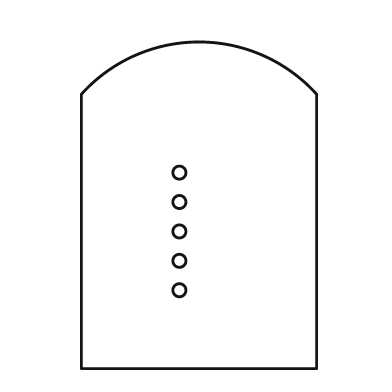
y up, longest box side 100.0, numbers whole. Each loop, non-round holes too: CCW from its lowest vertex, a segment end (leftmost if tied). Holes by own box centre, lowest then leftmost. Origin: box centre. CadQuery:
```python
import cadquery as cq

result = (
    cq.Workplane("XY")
    .moveTo(-36.0, -50.0)
    .lineTo(36.0, -50.0)
    .lineTo(36.0, 34.0)
    .threePointArc((0.0, 50.0), (-36.0, 34.0))
    .close()
    .moveTo(-6.0, -26.0)
    .circle(2.0)
    .moveTo(-6.0, -17.0)
    .circle(2.0)
    .moveTo(-6.0, -8.0)
    .circle(2.0)
    .moveTo(-6.0, 1.0)
    .circle(2.0)
    .moveTo(-6.0, 10.0)
    .circle(2.0)
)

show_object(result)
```